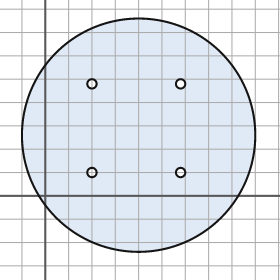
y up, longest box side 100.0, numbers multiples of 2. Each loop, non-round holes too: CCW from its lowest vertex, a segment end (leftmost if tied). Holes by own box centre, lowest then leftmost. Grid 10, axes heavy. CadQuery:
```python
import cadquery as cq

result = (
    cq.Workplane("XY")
    .moveTo(40.0, 26.0)
    .circle(50.0)
    .moveTo(20.0, 10.0)
    .circle(2.0)
    .moveTo(58.0, 10.0)
    .circle(2.0)
    .moveTo(20.0, 48.0)
    .circle(2.0)
    .moveTo(58.0, 48.0)
    .circle(2.0)
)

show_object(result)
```